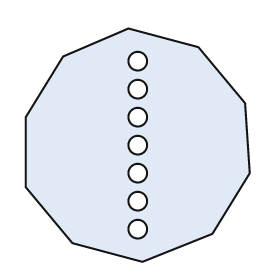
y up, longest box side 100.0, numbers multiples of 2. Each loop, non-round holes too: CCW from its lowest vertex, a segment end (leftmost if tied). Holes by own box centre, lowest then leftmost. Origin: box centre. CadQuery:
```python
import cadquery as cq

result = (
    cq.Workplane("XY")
    .moveTo(2.0, -50.0)
    .lineTo(32.0, -38.0)
    .lineTo(48.0, -12.0)
    .lineTo(46.0, 18.0)
    .lineTo(26.0, 42.0)
    .lineTo(-4.0, 50.0)
    .lineTo(-32.0, 38.0)
    .lineTo(-48.0, 12.0)
    .lineTo(-48.0, -18.0)
    .lineTo(-28.0, -42.0)
    .close()
    .moveTo(0.0, -36.0)
    .circle(4.0)
    .moveTo(0.0, -24.0)
    .circle(4.0)
    .moveTo(0.0, -12.0)
    .circle(4.0)
    .moveTo(0.0, 0.0)
    .circle(4.0)
    .moveTo(0.0, 12.0)
    .circle(4.0)
    .moveTo(0.0, 24.0)
    .circle(4.0)
    .moveTo(0.0, 36.0)
    .circle(4.0)
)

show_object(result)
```